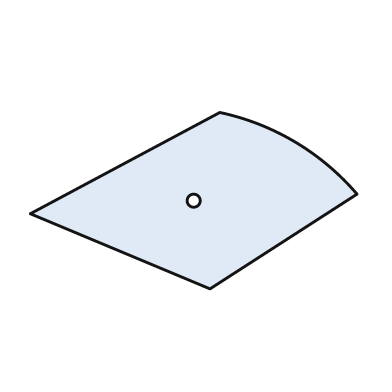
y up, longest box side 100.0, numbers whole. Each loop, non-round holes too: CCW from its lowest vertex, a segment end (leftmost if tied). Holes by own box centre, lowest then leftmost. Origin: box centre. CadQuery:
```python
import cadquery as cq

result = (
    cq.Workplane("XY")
    .moveTo(5.0, -27.0)
    .lineTo(50.0, 2.0)
    .threePointArc((31.0, 18.0), (8.0, 27.0))
    .lineTo(-50.0, -4.0)
    .close()
    .moveTo(0.0, 0.0)
    .circle(2.0)
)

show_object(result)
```